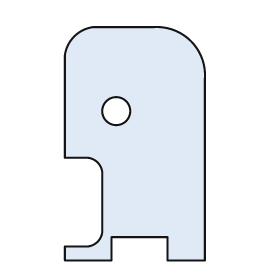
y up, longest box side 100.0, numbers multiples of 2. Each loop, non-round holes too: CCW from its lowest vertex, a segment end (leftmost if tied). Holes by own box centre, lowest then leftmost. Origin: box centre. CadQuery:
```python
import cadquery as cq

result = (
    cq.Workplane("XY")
    .moveTo(-30.0, -50.0)
    .lineTo(-10.0, -50.0)
    .lineTo(-10.0, -40.0)
    .lineTo(14.0, -40.0)
    .lineTo(14.0, -50.0)
    .lineTo(30.0, -50.0)
    .lineTo(30.0, 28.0)
    .threePointArc((24.0, 44.0), (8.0, 50.0))
    .lineTo(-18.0, 50.0)
    .threePointArc((-26.0, 46.0), (-30.0, 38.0))
    .lineTo(-30.0, -6.0)
    .lineTo(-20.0, -6.0)
    .threePointArc((-16.0, -8.0), (-14.0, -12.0))
    .lineTo(-14.0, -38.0)
    .threePointArc((-16.0, -42.0), (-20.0, -44.0))
    .lineTo(-30.0, -44.0)
    .close()
    .moveTo(-8.0, 14.0)
    .circle(6.0)
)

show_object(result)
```